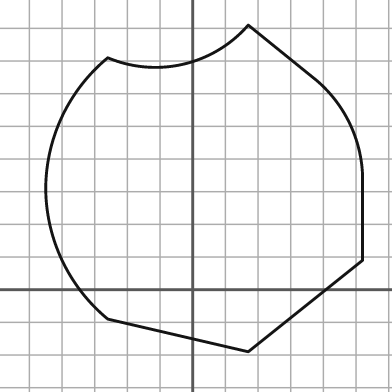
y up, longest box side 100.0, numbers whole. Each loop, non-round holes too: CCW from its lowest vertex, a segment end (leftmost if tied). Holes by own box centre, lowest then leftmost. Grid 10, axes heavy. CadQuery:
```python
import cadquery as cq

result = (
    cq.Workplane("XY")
    .moveTo(17.0, -19.0)
    .lineTo(52.0, 9.0)
    .lineTo(52.0, 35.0)
    .threePointArc((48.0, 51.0), (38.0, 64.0))
    .lineTo(17.0, 81.0)
    .threePointArc((-3.0, 69.0), (-26.0, 71.0))
    .threePointArc((-40.0, 53.0), (-45.0, 31.0))
    .threePointArc((-40.0, 9.0), (-26.0, -9.0))
    .close()
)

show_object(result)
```